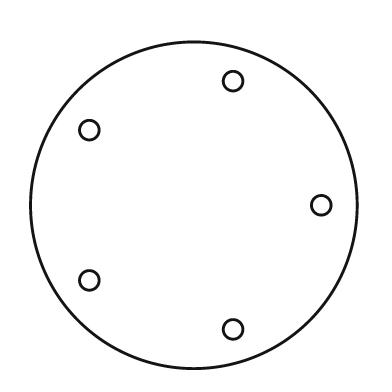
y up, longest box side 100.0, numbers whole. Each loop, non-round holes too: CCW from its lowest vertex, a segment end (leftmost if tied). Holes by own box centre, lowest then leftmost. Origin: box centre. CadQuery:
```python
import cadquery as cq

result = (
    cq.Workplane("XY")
    .moveTo(0.0, 0.0)
    .circle(50.0)
    .moveTo(12.0, -38.0)
    .circle(3.0)
    .moveTo(-32.0, -23.0)
    .circle(3.0)
    .moveTo(39.0, 0.0)
    .circle(3.0)
    .moveTo(-32.0, 23.0)
    .circle(3.0)
    .moveTo(12.0, 38.0)
    .circle(3.0)
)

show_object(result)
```